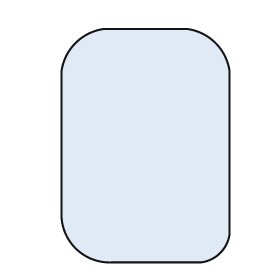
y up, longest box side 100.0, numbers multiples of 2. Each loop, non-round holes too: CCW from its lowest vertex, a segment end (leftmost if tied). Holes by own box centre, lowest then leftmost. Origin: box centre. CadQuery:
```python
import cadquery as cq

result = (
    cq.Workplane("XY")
    .moveTo(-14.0, -50.0)
    .lineTo(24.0, -50.0)
    .threePointArc((32.0, -46.0), (36.0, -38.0))
    .lineTo(36.0, 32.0)
    .threePointArc((30.0, 44.0), (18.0, 50.0))
    .lineTo(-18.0, 50.0)
    .threePointArc((-30.0, 44.0), (-36.0, 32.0))
    .lineTo(-36.0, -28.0)
    .threePointArc((-30.0, -44.0), (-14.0, -50.0))
    .close()
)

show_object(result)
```